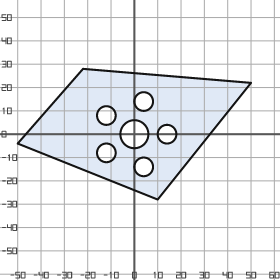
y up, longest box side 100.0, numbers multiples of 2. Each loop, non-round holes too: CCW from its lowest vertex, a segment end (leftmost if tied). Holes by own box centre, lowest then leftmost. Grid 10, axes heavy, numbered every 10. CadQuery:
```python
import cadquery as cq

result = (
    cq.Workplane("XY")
    .moveTo(10.0, -28.0)
    .lineTo(50.0, 22.0)
    .lineTo(-22.0, 28.0)
    .lineTo(-50.0, -4.0)
    .close()
    .moveTo(4.0, -14.0)
    .circle(4.0)
    .moveTo(-12.0, -8.0)
    .circle(4.0)
    .moveTo(0.0, 0.0)
    .circle(6.0)
    .moveTo(14.0, 0.0)
    .circle(4.0)
    .moveTo(-12.0, 8.0)
    .circle(4.0)
    .moveTo(4.0, 14.0)
    .circle(4.0)
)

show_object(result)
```